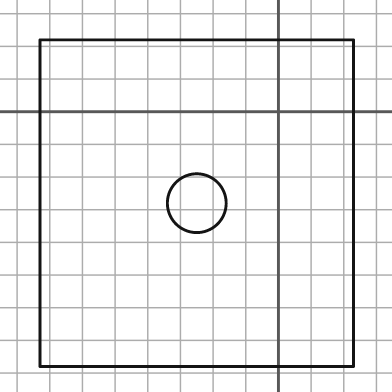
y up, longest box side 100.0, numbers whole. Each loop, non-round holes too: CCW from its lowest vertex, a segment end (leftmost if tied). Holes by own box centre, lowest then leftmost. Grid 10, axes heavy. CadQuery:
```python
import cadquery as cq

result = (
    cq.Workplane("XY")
    .moveTo(-73.0, -78.0)
    .lineTo(23.0, -78.0)
    .lineTo(23.0, 22.0)
    .lineTo(-73.0, 22.0)
    .close()
    .moveTo(-25.0, -28.0)
    .circle(9.0)
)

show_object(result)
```